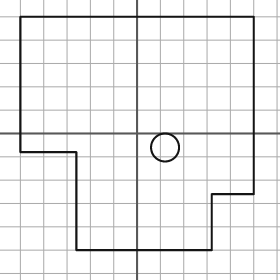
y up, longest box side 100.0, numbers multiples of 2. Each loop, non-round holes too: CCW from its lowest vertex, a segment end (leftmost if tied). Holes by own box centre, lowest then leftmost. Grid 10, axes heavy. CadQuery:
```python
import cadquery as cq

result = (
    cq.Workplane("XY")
    .moveTo(-26.0, -50.0)
    .lineTo(32.0, -50.0)
    .lineTo(32.0, -26.0)
    .lineTo(50.0, -26.0)
    .lineTo(50.0, 50.0)
    .lineTo(-50.0, 50.0)
    .lineTo(-50.0, -8.0)
    .lineTo(-26.0, -8.0)
    .close()
    .moveTo(12.0, -6.0)
    .circle(6.0)
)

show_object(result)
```